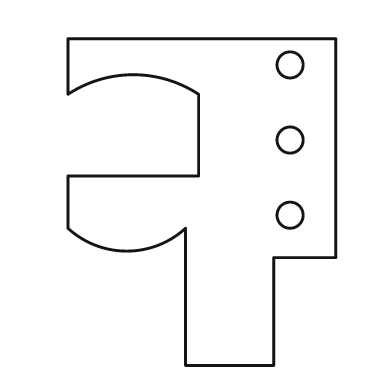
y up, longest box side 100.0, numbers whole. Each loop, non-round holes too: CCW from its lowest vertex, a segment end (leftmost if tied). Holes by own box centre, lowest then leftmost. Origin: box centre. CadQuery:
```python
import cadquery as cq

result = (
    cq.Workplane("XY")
    .moveTo(-5.0, -50.0)
    .lineTo(22.0, -50.0)
    .lineTo(22.0, -17.0)
    .lineTo(41.0, -17.0)
    .lineTo(41.0, 50.0)
    .lineTo(-41.0, 50.0)
    .lineTo(-41.0, 33.0)
    .threePointArc((-21.0, 39.0), (-1.0, 33.0))
    .lineTo(-1.0, 8.0)
    .lineTo(-41.0, 8.0)
    .lineTo(-41.0, -8.0)
    .threePointArc((-23.0, -15.0), (-5.0, -8.0))
    .close()
    .moveTo(27.0, -4.0)
    .circle(4.0)
    .moveTo(27.0, 19.0)
    .circle(4.0)
    .moveTo(27.0, 42.0)
    .circle(4.0)
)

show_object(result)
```